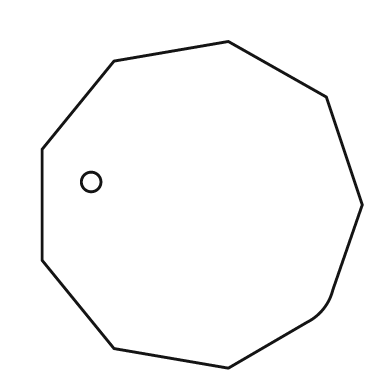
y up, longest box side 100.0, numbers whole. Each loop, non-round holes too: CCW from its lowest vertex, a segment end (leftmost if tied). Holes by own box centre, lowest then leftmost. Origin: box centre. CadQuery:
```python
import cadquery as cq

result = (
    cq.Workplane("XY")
    .moveTo(8.0, -50.0)
    .lineTo(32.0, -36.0)
    .threePointArc((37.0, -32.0), (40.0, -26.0))
    .lineTo(49.0, 0.0)
    .lineTo(38.0, 33.0)
    .lineTo(8.0, 50.0)
    .lineTo(-27.0, 44.0)
    .lineTo(-49.0, 17.0)
    .lineTo(-49.0, -17.0)
    .lineTo(-27.0, -44.0)
    .close()
    .moveTo(-34.0, 7.0)
    .circle(3.0)
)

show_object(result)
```